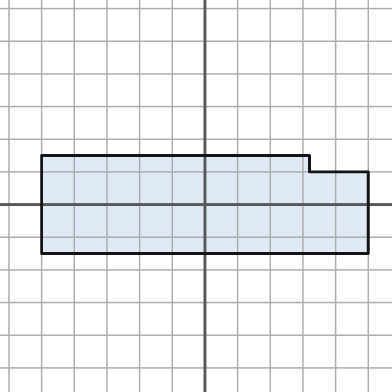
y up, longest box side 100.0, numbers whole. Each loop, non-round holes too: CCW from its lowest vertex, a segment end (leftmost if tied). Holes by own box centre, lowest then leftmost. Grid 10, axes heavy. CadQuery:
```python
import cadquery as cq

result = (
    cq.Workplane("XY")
    .moveTo(-50.0, -15.0)
    .lineTo(50.0, -15.0)
    .lineTo(50.0, 10.0)
    .lineTo(32.0, 10.0)
    .lineTo(32.0, 15.0)
    .lineTo(-50.0, 15.0)
    .close()
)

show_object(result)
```